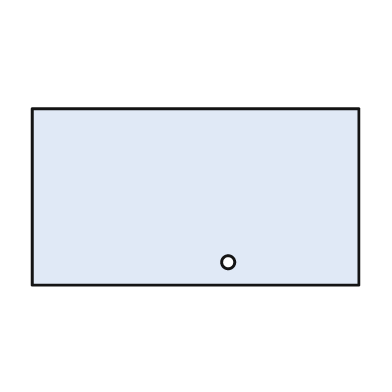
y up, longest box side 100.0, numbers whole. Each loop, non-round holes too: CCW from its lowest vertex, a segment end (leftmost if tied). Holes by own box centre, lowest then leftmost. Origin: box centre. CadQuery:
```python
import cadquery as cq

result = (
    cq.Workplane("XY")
    .moveTo(-50.0, -27.0)
    .lineTo(50.0, -27.0)
    .lineTo(50.0, 27.0)
    .lineTo(-50.0, 27.0)
    .close()
    .moveTo(10.0, -20.0)
    .circle(2.0)
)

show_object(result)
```